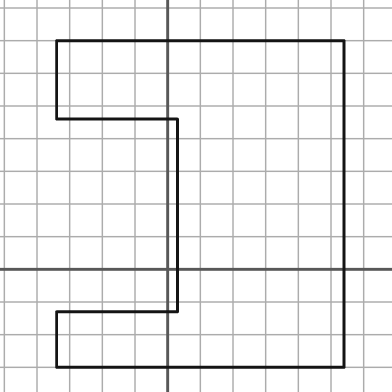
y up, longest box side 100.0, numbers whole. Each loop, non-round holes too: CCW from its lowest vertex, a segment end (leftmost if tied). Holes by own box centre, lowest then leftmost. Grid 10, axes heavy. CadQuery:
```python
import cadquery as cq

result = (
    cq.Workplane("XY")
    .moveTo(-34.0, -30.0)
    .lineTo(54.0, -30.0)
    .lineTo(54.0, 70.0)
    .lineTo(-34.0, 70.0)
    .lineTo(-34.0, 46.0)
    .lineTo(3.0, 46.0)
    .lineTo(3.0, -13.0)
    .lineTo(-34.0, -13.0)
    .close()
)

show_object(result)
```